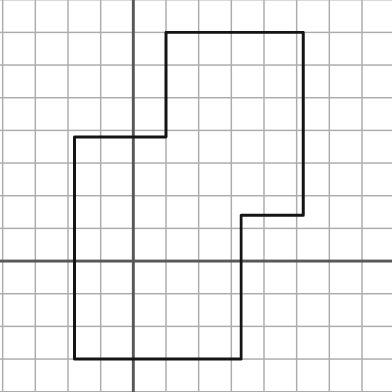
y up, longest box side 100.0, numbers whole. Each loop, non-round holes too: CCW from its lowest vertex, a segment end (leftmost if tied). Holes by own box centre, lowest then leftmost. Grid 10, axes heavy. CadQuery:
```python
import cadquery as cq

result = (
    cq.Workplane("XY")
    .moveTo(-18.0, -30.0)
    .lineTo(33.0, -30.0)
    .lineTo(33.0, 14.0)
    .lineTo(52.0, 14.0)
    .lineTo(52.0, 70.0)
    .lineTo(10.0, 70.0)
    .lineTo(10.0, 38.0)
    .lineTo(-18.0, 38.0)
    .close()
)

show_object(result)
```